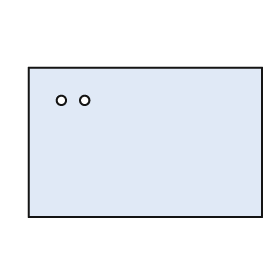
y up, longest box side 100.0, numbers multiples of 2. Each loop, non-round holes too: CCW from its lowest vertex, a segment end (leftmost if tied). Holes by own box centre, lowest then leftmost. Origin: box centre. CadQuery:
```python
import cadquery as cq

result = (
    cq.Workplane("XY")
    .moveTo(-50.0, -32.0)
    .lineTo(50.0, -32.0)
    .lineTo(50.0, 32.0)
    .lineTo(-50.0, 32.0)
    .close()
    .moveTo(-36.0, 18.0)
    .circle(2.0)
    .moveTo(-26.0, 18.0)
    .circle(2.0)
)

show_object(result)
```